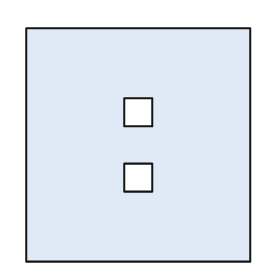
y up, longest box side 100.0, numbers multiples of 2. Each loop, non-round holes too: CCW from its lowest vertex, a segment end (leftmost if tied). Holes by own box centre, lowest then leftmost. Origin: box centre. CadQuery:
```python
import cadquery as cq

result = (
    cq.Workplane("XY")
    .moveTo(-48.0, -50.0)
    .lineTo(48.0, -50.0)
    .lineTo(48.0, 50.0)
    .lineTo(-48.0, 50.0)
    .close()
    .moveTo(-6.0, -20.0)
    .lineTo(6.0, -20.0)
    .lineTo(6.0, -8.0)
    .lineTo(-6.0, -8.0)
    .close()
    .moveTo(-6.0, 8.0)
    .lineTo(6.0, 8.0)
    .lineTo(6.0, 20.0)
    .lineTo(-6.0, 20.0)
    .close()
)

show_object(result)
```